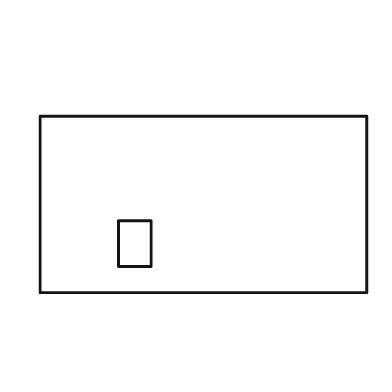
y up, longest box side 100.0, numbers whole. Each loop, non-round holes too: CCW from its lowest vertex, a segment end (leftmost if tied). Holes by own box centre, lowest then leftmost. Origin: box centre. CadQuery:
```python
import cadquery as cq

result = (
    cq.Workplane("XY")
    .moveTo(-50.0, -27.0)
    .lineTo(50.0, -27.0)
    .lineTo(50.0, 27.0)
    .lineTo(-50.0, 27.0)
    .close()
    .moveTo(-26.0, -19.0)
    .lineTo(-16.0, -19.0)
    .lineTo(-16.0, -5.0)
    .lineTo(-26.0, -5.0)
    .close()
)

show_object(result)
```